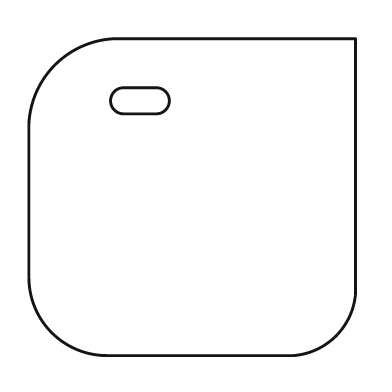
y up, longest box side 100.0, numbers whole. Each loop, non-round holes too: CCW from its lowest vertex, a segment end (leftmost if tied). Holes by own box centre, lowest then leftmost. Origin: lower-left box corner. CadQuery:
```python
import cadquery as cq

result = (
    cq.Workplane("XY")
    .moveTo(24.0, 0.0)
    .lineTo(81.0, 0.0)
    .threePointArc((94.0, 6.0), (100.0, 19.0))
    .lineTo(100.0, 97.0)
    .lineTo(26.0, 97.0)
    .threePointArc((8.0, 89.0), (0.0, 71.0))
    .lineTo(0.0, 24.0)
    .threePointArc((7.0, 7.0), (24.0, 0.0))
    .close()
    .moveTo(29.0, 74.0)
    .lineTo(39.0, 74.0)
    .threePointArc((43.0, 78.0), (39.0, 82.0))
    .lineTo(29.0, 82.0)
    .threePointArc((25.0, 78.0), (29.0, 74.0))
    .close()
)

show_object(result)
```